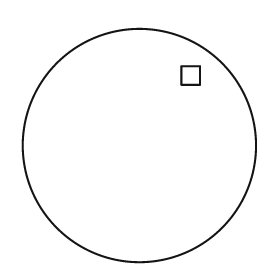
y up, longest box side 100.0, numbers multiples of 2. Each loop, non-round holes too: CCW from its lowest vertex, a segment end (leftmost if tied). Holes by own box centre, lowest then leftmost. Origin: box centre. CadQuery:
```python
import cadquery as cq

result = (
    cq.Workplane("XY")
    .moveTo(0.0, 0.0)
    .circle(50.0)
    .moveTo(18.0, 26.0)
    .lineTo(26.0, 26.0)
    .lineTo(26.0, 34.0)
    .lineTo(18.0, 34.0)
    .close()
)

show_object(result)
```